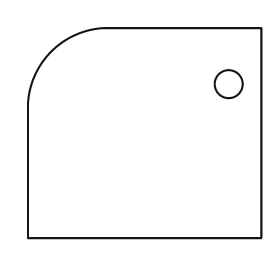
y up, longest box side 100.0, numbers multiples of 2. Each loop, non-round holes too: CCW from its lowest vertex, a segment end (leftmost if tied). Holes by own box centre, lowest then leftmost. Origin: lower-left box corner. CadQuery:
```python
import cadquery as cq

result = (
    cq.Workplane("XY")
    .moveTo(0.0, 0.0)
    .lineTo(100.0, 0.0)
    .lineTo(100.0, 90.0)
    .lineTo(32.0, 90.0)
    .threePointArc((10.0, 80.0), (0.0, 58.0))
    .close()
    .moveTo(86.0, 66.0)
    .circle(6.0)
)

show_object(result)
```